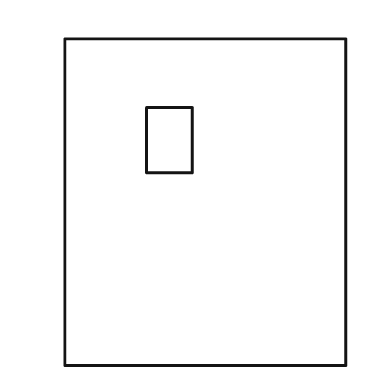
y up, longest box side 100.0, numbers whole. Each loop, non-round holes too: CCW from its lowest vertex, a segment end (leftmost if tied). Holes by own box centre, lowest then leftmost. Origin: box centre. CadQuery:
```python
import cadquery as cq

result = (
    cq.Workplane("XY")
    .moveTo(-43.0, -50.0)
    .lineTo(43.0, -50.0)
    .lineTo(43.0, 50.0)
    .lineTo(-43.0, 50.0)
    .close()
    .moveTo(-18.0, 9.0)
    .lineTo(-4.0, 9.0)
    .lineTo(-4.0, 29.0)
    .lineTo(-18.0, 29.0)
    .close()
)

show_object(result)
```